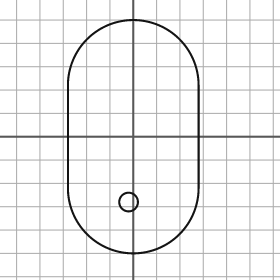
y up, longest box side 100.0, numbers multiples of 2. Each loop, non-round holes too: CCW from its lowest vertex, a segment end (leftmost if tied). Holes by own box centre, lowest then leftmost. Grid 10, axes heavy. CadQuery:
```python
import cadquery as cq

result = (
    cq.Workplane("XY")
    .moveTo(-28.0, -22.0)
    .threePointArc((0.0, -50.0), (28.0, -22.0))
    .lineTo(28.0, 22.0)
    .threePointArc((0.0, 50.0), (-28.0, 22.0))
    .close()
    .moveTo(-2.0, -28.0)
    .circle(4.0)
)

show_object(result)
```